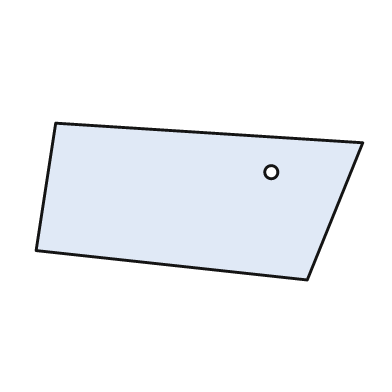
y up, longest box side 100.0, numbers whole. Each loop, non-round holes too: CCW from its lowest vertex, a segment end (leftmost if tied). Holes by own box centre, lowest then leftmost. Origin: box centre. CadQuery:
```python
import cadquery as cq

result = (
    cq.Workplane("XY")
    .moveTo(33.0, -24.0)
    .lineTo(50.0, 18.0)
    .lineTo(-44.0, 24.0)
    .lineTo(-50.0, -15.0)
    .close()
    .moveTo(22.0, 9.0)
    .circle(2.0)
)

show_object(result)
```